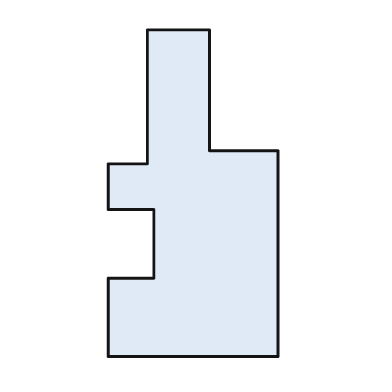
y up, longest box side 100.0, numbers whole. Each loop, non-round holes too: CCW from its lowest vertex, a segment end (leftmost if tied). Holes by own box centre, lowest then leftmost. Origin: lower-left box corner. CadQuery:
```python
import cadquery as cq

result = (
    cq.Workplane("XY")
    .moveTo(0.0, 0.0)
    .lineTo(52.0, 0.0)
    .lineTo(52.0, 63.0)
    .lineTo(31.0, 63.0)
    .lineTo(31.0, 100.0)
    .lineTo(12.0, 100.0)
    .lineTo(12.0, 59.0)
    .lineTo(0.0, 59.0)
    .lineTo(0.0, 45.0)
    .lineTo(14.0, 45.0)
    .lineTo(14.0, 24.0)
    .lineTo(0.0, 24.0)
    .close()
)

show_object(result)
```